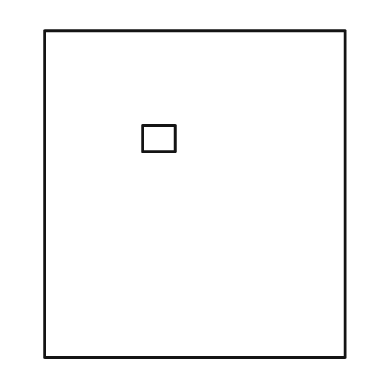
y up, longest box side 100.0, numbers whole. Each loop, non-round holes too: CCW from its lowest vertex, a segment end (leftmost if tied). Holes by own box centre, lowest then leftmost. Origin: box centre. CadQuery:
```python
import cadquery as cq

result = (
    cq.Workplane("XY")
    .moveTo(-46.0, -50.0)
    .lineTo(46.0, -50.0)
    .lineTo(46.0, 50.0)
    .lineTo(-46.0, 50.0)
    .close()
    .moveTo(-16.0, 13.0)
    .lineTo(-6.0, 13.0)
    .lineTo(-6.0, 21.0)
    .lineTo(-16.0, 21.0)
    .close()
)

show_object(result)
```